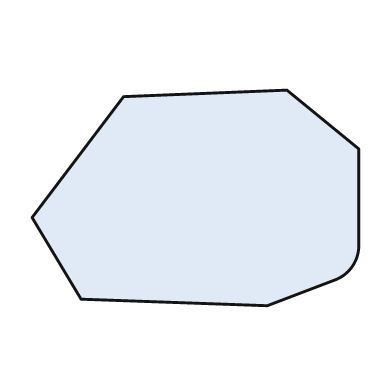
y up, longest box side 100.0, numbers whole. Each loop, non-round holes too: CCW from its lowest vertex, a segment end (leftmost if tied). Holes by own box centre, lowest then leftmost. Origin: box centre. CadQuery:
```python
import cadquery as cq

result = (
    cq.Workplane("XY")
    .moveTo(22.0, -33.0)
    .lineTo(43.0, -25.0)
    .threePointArc((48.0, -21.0), (50.0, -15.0))
    .lineTo(50.0, 15.0)
    .lineTo(28.0, 33.0)
    .lineTo(-22.0, 31.0)
    .lineTo(-50.0, -6.0)
    .lineTo(-35.0, -31.0)
    .close()
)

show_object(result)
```